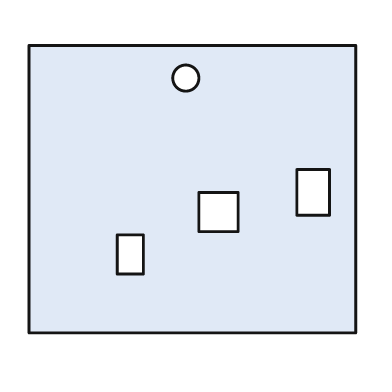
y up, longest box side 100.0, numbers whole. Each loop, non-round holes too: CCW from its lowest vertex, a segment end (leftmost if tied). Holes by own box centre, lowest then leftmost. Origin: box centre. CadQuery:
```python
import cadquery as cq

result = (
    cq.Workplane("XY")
    .moveTo(-50.0, -44.0)
    .lineTo(50.0, -44.0)
    .lineTo(50.0, 44.0)
    .lineTo(-50.0, 44.0)
    .close()
    .moveTo(-23.0, -26.0)
    .lineTo(-15.0, -26.0)
    .lineTo(-15.0, -14.0)
    .lineTo(-23.0, -14.0)
    .close()
    .moveTo(2.0, -13.0)
    .lineTo(14.0, -13.0)
    .lineTo(14.0, -1.0)
    .lineTo(2.0, -1.0)
    .close()
    .moveTo(32.0, -8.0)
    .lineTo(42.0, -8.0)
    .lineTo(42.0, 6.0)
    .lineTo(32.0, 6.0)
    .close()
    .moveTo(-2.0, 34.0)
    .circle(4.0)
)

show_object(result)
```